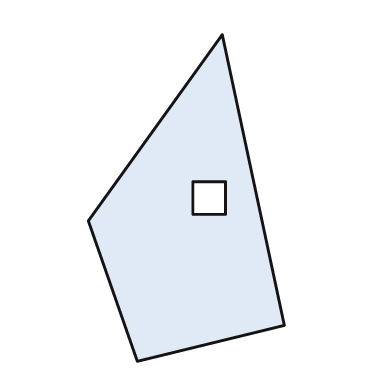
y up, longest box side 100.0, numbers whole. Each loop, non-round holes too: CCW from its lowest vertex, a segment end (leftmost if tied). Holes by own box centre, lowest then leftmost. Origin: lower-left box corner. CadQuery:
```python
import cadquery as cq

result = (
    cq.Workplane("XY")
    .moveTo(15.0, 0.0)
    .lineTo(60.0, 11.0)
    .lineTo(41.0, 100.0)
    .lineTo(0.0, 43.0)
    .close()
    .moveTo(32.0, 45.0)
    .lineTo(42.0, 45.0)
    .lineTo(42.0, 55.0)
    .lineTo(32.0, 55.0)
    .close()
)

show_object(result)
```